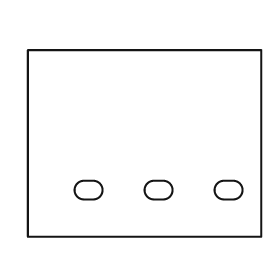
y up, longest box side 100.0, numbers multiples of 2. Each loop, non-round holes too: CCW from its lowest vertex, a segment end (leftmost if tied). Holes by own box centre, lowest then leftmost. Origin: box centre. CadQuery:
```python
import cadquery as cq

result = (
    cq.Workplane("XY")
    .moveTo(-50.0, -40.0)
    .lineTo(50.0, -40.0)
    .lineTo(50.0, 40.0)
    .lineTo(-50.0, 40.0)
    .close()
    .moveTo(-26.0, -24.0)
    .lineTo(-22.0, -24.0)
    .threePointArc((-18.0, -20.0), (-22.0, -16.0))
    .lineTo(-26.0, -16.0)
    .threePointArc((-30.0, -20.0), (-26.0, -24.0))
    .close()
    .moveTo(4.0, -24.0)
    .lineTo(8.0, -24.0)
    .threePointArc((12.0, -20.0), (8.0, -16.0))
    .lineTo(4.0, -16.0)
    .threePointArc((0.0, -20.0), (4.0, -24.0))
    .close()
    .moveTo(34.0, -24.0)
    .lineTo(38.0, -24.0)
    .threePointArc((42.0, -20.0), (38.0, -16.0))
    .lineTo(34.0, -16.0)
    .threePointArc((30.0, -20.0), (34.0, -24.0))
    .close()
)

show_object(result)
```